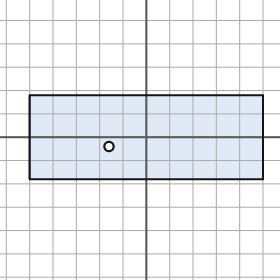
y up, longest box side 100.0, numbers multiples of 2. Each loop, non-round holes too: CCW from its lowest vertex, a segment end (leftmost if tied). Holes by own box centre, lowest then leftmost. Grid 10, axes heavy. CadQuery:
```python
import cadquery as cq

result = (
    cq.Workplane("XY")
    .moveTo(-50.0, -18.0)
    .lineTo(50.0, -18.0)
    .lineTo(50.0, 18.0)
    .lineTo(-50.0, 18.0)
    .close()
    .moveTo(-16.0, -4.0)
    .circle(2.0)
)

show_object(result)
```